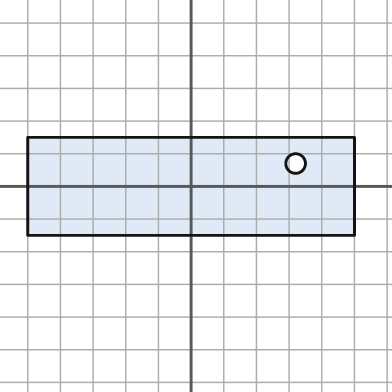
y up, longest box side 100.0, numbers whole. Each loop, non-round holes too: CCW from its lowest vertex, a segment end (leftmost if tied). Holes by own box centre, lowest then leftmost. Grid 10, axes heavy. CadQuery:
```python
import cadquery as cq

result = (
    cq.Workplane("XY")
    .moveTo(-50.0, -15.0)
    .lineTo(50.0, -15.0)
    .lineTo(50.0, 15.0)
    .lineTo(-50.0, 15.0)
    .close()
    .moveTo(32.0, 7.0)
    .circle(3.0)
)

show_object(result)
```